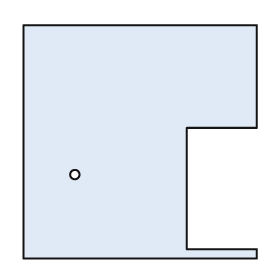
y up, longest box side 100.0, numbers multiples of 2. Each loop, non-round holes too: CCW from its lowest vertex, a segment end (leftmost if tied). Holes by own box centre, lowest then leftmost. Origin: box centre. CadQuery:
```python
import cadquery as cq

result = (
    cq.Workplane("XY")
    .moveTo(-50.0, -50.0)
    .lineTo(50.0, -50.0)
    .lineTo(50.0, -46.0)
    .lineTo(20.0, -46.0)
    .lineTo(20.0, 6.0)
    .lineTo(50.0, 6.0)
    .lineTo(50.0, 50.0)
    .lineTo(-50.0, 50.0)
    .close()
    .moveTo(-28.0, -14.0)
    .circle(2.0)
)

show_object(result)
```